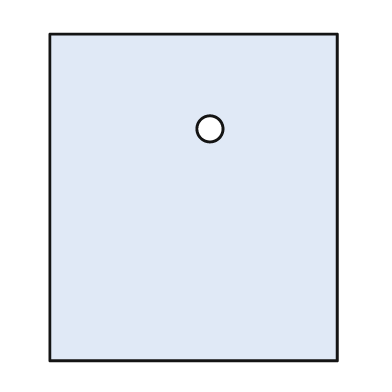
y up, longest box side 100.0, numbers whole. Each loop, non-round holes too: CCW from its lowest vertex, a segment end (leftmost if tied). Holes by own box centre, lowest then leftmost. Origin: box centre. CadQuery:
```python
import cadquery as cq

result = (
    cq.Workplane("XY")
    .moveTo(-44.0, -50.0)
    .lineTo(44.0, -50.0)
    .lineTo(44.0, 50.0)
    .lineTo(-44.0, 50.0)
    .close()
    .moveTo(5.0, 21.0)
    .circle(4.0)
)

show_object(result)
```